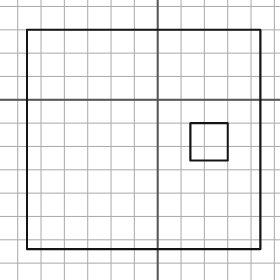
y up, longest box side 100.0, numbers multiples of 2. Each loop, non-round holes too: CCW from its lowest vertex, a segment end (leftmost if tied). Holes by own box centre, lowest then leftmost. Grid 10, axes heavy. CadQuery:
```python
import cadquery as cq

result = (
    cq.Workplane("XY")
    .moveTo(-56.0, -64.0)
    .lineTo(44.0, -64.0)
    .lineTo(44.0, 30.0)
    .lineTo(-56.0, 30.0)
    .close()
    .moveTo(14.0, -26.0)
    .lineTo(30.0, -26.0)
    .lineTo(30.0, -10.0)
    .lineTo(14.0, -10.0)
    .close()
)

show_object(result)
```